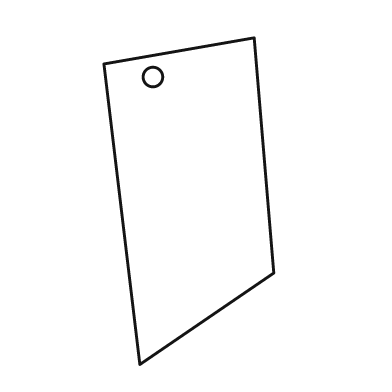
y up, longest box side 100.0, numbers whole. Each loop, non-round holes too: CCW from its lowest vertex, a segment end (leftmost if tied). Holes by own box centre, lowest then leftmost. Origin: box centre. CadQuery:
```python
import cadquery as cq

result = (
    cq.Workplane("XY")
    .moveTo(-15.0, -50.0)
    .lineTo(26.0, -22.0)
    .lineTo(20.0, 50.0)
    .lineTo(-26.0, 42.0)
    .close()
    .moveTo(-11.0, 38.0)
    .circle(3.0)
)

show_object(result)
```